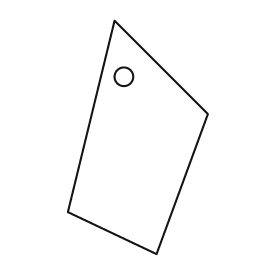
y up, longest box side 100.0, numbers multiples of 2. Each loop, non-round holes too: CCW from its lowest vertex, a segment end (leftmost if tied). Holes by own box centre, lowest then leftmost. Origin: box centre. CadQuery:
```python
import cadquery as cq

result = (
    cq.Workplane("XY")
    .moveTo(8.0, -50.0)
    .lineTo(30.0, 10.0)
    .lineTo(-10.0, 50.0)
    .lineTo(-30.0, -32.0)
    .close()
    .moveTo(-6.0, 26.0)
    .circle(4.0)
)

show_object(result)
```